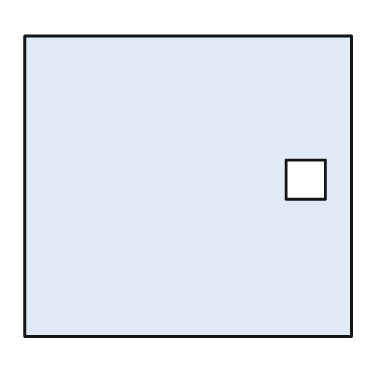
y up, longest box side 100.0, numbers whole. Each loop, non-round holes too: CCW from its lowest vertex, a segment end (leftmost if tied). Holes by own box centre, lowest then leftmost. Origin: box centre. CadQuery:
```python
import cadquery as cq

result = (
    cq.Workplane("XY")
    .moveTo(-50.0, -46.0)
    .lineTo(50.0, -46.0)
    .lineTo(50.0, 46.0)
    .lineTo(-50.0, 46.0)
    .close()
    .moveTo(30.0, -4.0)
    .lineTo(42.0, -4.0)
    .lineTo(42.0, 8.0)
    .lineTo(30.0, 8.0)
    .close()
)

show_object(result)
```